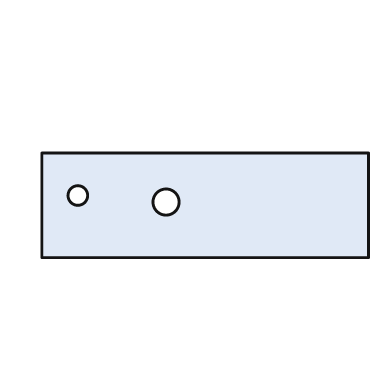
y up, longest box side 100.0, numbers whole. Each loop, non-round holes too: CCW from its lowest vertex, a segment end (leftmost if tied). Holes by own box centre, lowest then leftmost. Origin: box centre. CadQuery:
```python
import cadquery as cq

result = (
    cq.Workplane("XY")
    .moveTo(-50.0, -16.0)
    .lineTo(50.0, -16.0)
    .lineTo(50.0, 16.0)
    .lineTo(-50.0, 16.0)
    .close()
    .moveTo(-12.0, 1.0)
    .circle(4.0)
    .moveTo(-39.0, 3.0)
    .circle(3.0)
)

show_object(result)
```